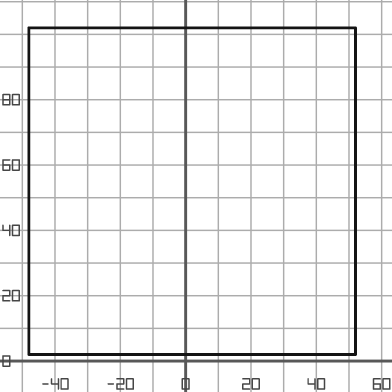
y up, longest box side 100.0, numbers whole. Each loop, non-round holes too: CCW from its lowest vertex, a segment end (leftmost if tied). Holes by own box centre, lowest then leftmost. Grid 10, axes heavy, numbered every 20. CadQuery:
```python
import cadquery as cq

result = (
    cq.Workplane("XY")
    .moveTo(-48.0, 2.0)
    .lineTo(52.0, 2.0)
    .lineTo(52.0, 102.0)
    .lineTo(-48.0, 102.0)
    .close()
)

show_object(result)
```